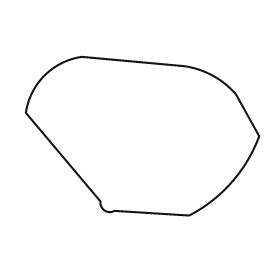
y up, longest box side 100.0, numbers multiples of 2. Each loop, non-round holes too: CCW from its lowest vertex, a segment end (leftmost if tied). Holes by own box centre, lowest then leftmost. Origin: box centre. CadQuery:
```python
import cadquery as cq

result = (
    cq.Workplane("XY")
    .moveTo(20.0, -34.0)
    .threePointArc((38.0, -20.0), (50.0, 0.0))
    .lineTo(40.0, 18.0)
    .threePointArc((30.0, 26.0), (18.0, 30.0))
    .lineTo(-26.0, 34.0)
    .threePointArc((-42.0, 26.0), (-50.0, 10.0))
    .lineTo(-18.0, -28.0)
    .threePointArc((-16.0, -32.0), (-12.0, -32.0))
    .close()
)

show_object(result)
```